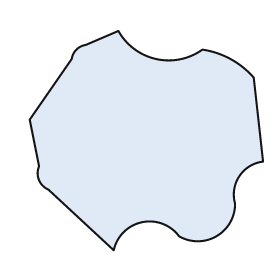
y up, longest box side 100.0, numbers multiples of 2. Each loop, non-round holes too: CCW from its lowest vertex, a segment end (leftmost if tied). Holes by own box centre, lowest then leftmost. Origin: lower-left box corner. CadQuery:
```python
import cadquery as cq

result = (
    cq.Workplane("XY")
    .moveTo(36.0, 0.0)
    .threePointArc((48.0, 12.0), (64.0, 6.0))
    .threePointArc((80.0, 6.0), (88.0, 20.0))
    .threePointArc((90.0, 32.0), (100.0, 38.0))
    .lineTo(96.0, 74.0)
    .threePointArc((86.0, 82.0), (74.0, 86.0))
    .threePointArc((54.0, 82.0), (38.0, 94.0))
    .lineTo(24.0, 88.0)
    .threePointArc((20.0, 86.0), (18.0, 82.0))
    .lineTo(0.0, 56.0)
    .lineTo(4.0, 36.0)
    .threePointArc((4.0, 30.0), (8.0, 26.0))
    .close()
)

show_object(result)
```